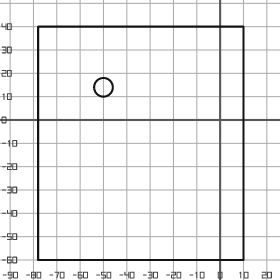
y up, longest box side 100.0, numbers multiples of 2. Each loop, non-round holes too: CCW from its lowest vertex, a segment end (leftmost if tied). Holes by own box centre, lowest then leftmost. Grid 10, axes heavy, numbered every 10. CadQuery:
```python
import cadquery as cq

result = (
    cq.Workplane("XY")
    .moveTo(-78.0, -60.0)
    .lineTo(10.0, -60.0)
    .lineTo(10.0, 40.0)
    .lineTo(-78.0, 40.0)
    .close()
    .moveTo(-50.0, 14.0)
    .circle(4.0)
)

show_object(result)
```